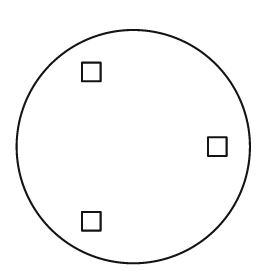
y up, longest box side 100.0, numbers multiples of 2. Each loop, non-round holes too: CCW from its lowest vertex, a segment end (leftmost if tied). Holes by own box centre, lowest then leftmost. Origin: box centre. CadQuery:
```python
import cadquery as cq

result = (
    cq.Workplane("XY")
    .moveTo(0.0, 0.0)
    .circle(50.0)
    .moveTo(-22.0, -36.0)
    .lineTo(-14.0, -36.0)
    .lineTo(-14.0, -28.0)
    .lineTo(-22.0, -28.0)
    .close()
    .moveTo(32.0, -4.0)
    .lineTo(40.0, -4.0)
    .lineTo(40.0, 4.0)
    .lineTo(32.0, 4.0)
    .close()
    .moveTo(-22.0, 28.0)
    .lineTo(-14.0, 28.0)
    .lineTo(-14.0, 36.0)
    .lineTo(-22.0, 36.0)
    .close()
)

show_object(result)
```